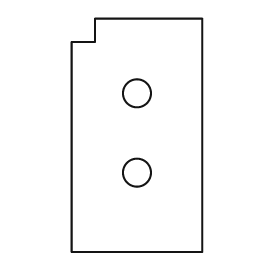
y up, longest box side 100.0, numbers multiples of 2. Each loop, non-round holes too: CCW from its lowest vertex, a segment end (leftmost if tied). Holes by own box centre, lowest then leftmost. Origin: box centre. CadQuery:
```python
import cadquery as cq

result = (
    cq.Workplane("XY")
    .moveTo(-28.0, -50.0)
    .lineTo(28.0, -50.0)
    .lineTo(28.0, 50.0)
    .lineTo(-18.0, 50.0)
    .lineTo(-18.0, 40.0)
    .lineTo(-28.0, 40.0)
    .close()
    .moveTo(0.0, -16.0)
    .circle(6.0)
    .moveTo(0.0, 18.0)
    .circle(6.0)
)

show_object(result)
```